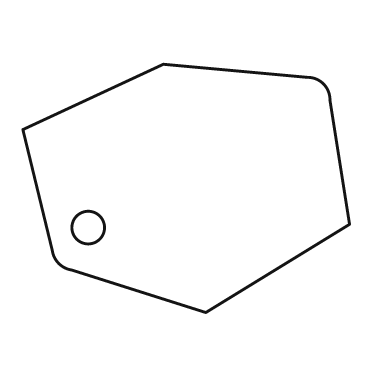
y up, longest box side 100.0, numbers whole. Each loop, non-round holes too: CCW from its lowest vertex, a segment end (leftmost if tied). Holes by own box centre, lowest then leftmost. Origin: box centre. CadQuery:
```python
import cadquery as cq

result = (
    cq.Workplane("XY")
    .moveTo(6.0, -38.0)
    .lineTo(50.0, -11.0)
    .lineTo(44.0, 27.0)
    .threePointArc((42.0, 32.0), (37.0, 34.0))
    .lineTo(-7.0, 38.0)
    .lineTo(-50.0, 18.0)
    .lineTo(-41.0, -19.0)
    .threePointArc((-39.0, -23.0), (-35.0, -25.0))
    .close()
    .moveTo(-30.0, -12.0)
    .circle(5.0)
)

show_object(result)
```